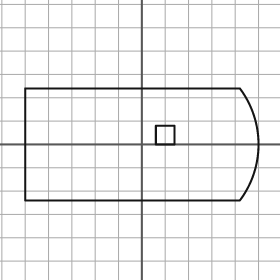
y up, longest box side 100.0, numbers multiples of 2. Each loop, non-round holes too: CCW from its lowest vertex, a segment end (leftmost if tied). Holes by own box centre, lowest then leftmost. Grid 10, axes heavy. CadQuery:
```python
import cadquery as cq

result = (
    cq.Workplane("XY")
    .moveTo(-50.0, -24.0)
    .lineTo(42.0, -24.0)
    .threePointArc((50.0, 0.0), (42.0, 24.0))
    .lineTo(-50.0, 24.0)
    .close()
    .moveTo(6.0, 0.0)
    .lineTo(14.0, 0.0)
    .lineTo(14.0, 8.0)
    .lineTo(6.0, 8.0)
    .close()
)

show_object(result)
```